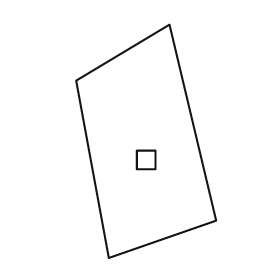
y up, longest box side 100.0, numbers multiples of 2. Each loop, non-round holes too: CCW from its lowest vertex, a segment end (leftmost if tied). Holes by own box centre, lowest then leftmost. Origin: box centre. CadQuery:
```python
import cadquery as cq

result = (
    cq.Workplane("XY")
    .moveTo(-16.0, -50.0)
    .lineTo(30.0, -34.0)
    .lineTo(10.0, 50.0)
    .lineTo(-30.0, 26.0)
    .close()
    .moveTo(-4.0, -12.0)
    .lineTo(4.0, -12.0)
    .lineTo(4.0, -4.0)
    .lineTo(-4.0, -4.0)
    .close()
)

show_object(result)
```